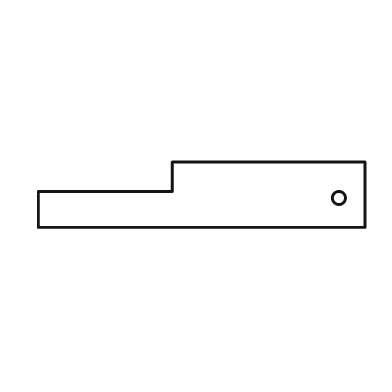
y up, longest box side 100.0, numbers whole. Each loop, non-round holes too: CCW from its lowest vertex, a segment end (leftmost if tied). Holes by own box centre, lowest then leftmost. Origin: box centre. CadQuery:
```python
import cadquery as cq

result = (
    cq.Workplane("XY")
    .moveTo(-50.0, -10.0)
    .lineTo(50.0, -10.0)
    .lineTo(50.0, 10.0)
    .lineTo(-9.0, 10.0)
    .lineTo(-9.0, 1.0)
    .lineTo(-50.0, 1.0)
    .close()
    .moveTo(42.0, -1.0)
    .circle(2.0)
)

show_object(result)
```